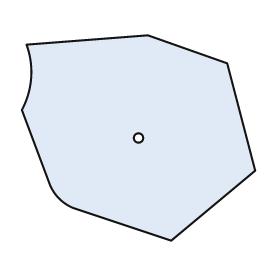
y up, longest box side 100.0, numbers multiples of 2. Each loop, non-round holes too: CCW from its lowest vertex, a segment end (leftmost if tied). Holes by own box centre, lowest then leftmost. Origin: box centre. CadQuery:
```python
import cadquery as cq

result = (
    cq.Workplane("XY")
    .moveTo(14.0, -44.0)
    .lineTo(50.0, -14.0)
    .lineTo(38.0, 32.0)
    .lineTo(4.0, 44.0)
    .lineTo(-48.0, 40.0)
    .threePointArc((-46.0, 26.0), (-50.0, 12.0))
    .lineTo(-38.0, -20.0)
    .threePointArc((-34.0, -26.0), (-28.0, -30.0))
    .close()
    .moveTo(0.0, 0.0)
    .circle(2.0)
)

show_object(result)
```